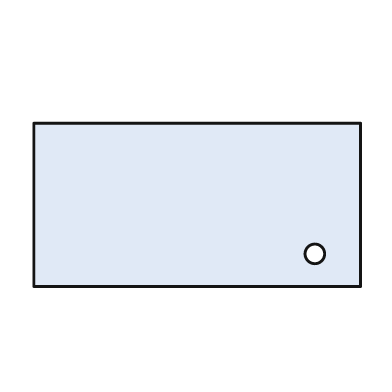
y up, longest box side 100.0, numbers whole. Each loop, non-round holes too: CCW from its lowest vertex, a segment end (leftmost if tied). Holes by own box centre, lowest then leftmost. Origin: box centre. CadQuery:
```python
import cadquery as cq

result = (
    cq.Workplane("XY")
    .moveTo(-50.0, -25.0)
    .lineTo(50.0, -25.0)
    .lineTo(50.0, 25.0)
    .lineTo(-50.0, 25.0)
    .close()
    .moveTo(36.0, -15.0)
    .circle(3.0)
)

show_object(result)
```